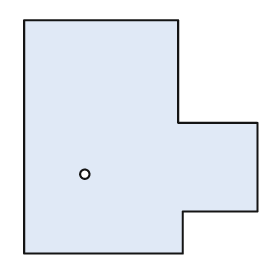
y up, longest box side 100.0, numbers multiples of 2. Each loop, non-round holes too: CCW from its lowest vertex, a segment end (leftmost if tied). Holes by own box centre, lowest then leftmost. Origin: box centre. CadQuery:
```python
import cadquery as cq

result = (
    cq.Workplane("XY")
    .moveTo(-50.0, -50.0)
    .lineTo(18.0, -50.0)
    .lineTo(18.0, -32.0)
    .lineTo(50.0, -32.0)
    .lineTo(50.0, 6.0)
    .lineTo(16.0, 6.0)
    .lineTo(16.0, 50.0)
    .lineTo(-50.0, 50.0)
    .close()
    .moveTo(-24.0, -16.0)
    .circle(2.0)
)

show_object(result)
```